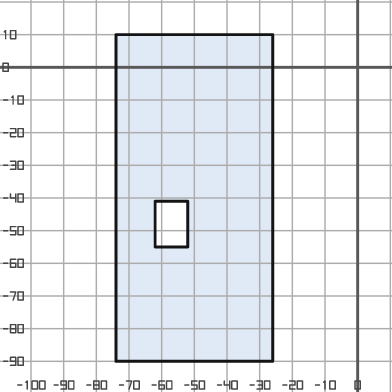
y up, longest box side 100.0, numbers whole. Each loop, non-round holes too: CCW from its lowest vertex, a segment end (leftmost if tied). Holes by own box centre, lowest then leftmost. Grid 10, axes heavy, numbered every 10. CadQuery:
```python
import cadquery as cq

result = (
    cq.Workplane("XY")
    .moveTo(-74.0, -90.0)
    .lineTo(-26.0, -90.0)
    .lineTo(-26.0, 10.0)
    .lineTo(-74.0, 10.0)
    .close()
    .moveTo(-62.0, -55.0)
    .lineTo(-52.0, -55.0)
    .lineTo(-52.0, -41.0)
    .lineTo(-62.0, -41.0)
    .close()
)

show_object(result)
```